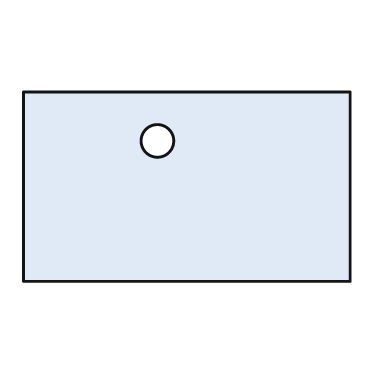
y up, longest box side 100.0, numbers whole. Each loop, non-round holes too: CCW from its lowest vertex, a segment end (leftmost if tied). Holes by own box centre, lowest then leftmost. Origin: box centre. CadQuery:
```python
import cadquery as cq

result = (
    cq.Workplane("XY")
    .moveTo(-50.0, -29.0)
    .lineTo(50.0, -29.0)
    .lineTo(50.0, 29.0)
    .lineTo(-50.0, 29.0)
    .close()
    .moveTo(-9.0, 14.0)
    .circle(5.0)
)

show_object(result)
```